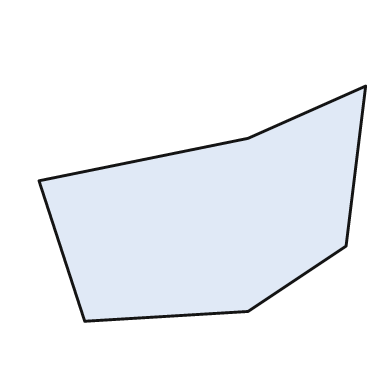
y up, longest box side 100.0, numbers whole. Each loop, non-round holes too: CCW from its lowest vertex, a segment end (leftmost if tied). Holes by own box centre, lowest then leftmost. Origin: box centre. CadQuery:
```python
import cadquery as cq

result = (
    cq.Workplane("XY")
    .moveTo(-36.0, -36.0)
    .lineTo(14.0, -33.0)
    .lineTo(44.0, -13.0)
    .lineTo(50.0, 36.0)
    .lineTo(14.0, 20.0)
    .lineTo(-50.0, 7.0)
    .close()
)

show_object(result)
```